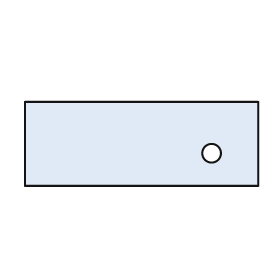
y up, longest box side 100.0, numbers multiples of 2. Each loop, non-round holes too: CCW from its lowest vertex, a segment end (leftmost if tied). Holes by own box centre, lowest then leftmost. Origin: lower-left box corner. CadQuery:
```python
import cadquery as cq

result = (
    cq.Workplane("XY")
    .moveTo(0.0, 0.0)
    .lineTo(100.0, 0.0)
    .lineTo(100.0, 36.0)
    .lineTo(0.0, 36.0)
    .close()
    .moveTo(80.0, 14.0)
    .circle(4.0)
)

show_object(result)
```